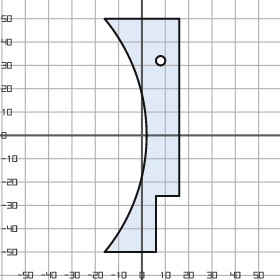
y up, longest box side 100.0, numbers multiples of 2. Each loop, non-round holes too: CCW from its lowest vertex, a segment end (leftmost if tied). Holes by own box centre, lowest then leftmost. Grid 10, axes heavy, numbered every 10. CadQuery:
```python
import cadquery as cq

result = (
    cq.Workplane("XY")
    .moveTo(-16.0, -50.0)
    .lineTo(6.0, -50.0)
    .lineTo(6.0, -26.0)
    .lineTo(16.0, -26.0)
    .lineTo(16.0, 50.0)
    .lineTo(-16.0, 50.0)
    .threePointArc((2.0, 0.0), (-16.0, -50.0))
    .close()
    .moveTo(8.0, 32.0)
    .circle(2.0)
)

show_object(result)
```